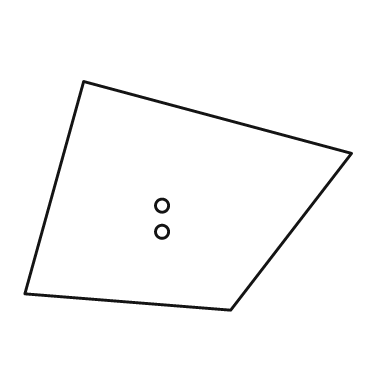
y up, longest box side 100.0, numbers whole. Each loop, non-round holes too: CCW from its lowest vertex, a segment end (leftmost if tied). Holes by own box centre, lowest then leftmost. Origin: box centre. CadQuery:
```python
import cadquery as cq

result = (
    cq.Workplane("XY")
    .moveTo(13.0, -35.0)
    .lineTo(50.0, 13.0)
    .lineTo(-32.0, 35.0)
    .lineTo(-50.0, -30.0)
    .close()
    .moveTo(-8.0, -11.0)
    .circle(2.0)
    .moveTo(-8.0, -3.0)
    .circle(2.0)
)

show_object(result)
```